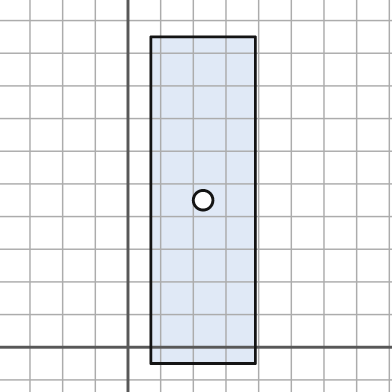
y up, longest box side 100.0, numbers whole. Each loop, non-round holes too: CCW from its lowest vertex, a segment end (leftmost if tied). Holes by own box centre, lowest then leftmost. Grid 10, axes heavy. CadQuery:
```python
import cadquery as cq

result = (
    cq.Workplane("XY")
    .moveTo(7.0, -5.0)
    .lineTo(39.0, -5.0)
    .lineTo(39.0, 95.0)
    .lineTo(7.0, 95.0)
    .close()
    .moveTo(23.0, 45.0)
    .circle(3.0)
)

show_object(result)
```